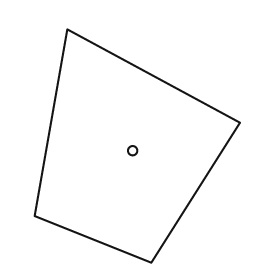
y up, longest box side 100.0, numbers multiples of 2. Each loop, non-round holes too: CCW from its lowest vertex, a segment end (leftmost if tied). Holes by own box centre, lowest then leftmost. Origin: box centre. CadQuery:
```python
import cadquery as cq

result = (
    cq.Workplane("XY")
    .moveTo(6.0, -50.0)
    .lineTo(44.0, 10.0)
    .lineTo(-30.0, 50.0)
    .lineTo(-44.0, -30.0)
    .close()
    .moveTo(-2.0, -2.0)
    .circle(2.0)
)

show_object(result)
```